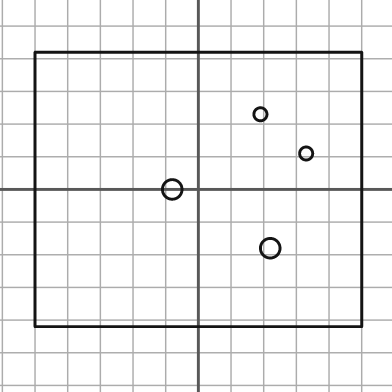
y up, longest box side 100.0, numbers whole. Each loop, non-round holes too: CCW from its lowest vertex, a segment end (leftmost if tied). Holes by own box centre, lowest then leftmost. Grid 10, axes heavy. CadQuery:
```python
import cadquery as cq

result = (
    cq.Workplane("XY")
    .moveTo(-50.0, -42.0)
    .lineTo(50.0, -42.0)
    .lineTo(50.0, 42.0)
    .lineTo(-50.0, 42.0)
    .close()
    .moveTo(22.0, -18.0)
    .circle(3.0)
    .moveTo(-8.0, 0.0)
    .circle(3.0)
    .moveTo(33.0, 11.0)
    .circle(2.0)
    .moveTo(19.0, 23.0)
    .circle(2.0)
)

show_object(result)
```